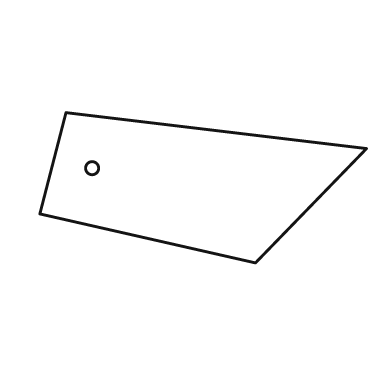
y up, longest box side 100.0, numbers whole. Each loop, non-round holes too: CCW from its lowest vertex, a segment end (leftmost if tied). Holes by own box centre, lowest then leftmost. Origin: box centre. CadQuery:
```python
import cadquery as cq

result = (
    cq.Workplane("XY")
    .moveTo(16.0, -23.0)
    .lineTo(50.0, 12.0)
    .lineTo(-42.0, 23.0)
    .lineTo(-50.0, -8.0)
    .close()
    .moveTo(-34.0, 6.0)
    .circle(2.0)
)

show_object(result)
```